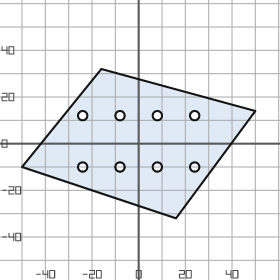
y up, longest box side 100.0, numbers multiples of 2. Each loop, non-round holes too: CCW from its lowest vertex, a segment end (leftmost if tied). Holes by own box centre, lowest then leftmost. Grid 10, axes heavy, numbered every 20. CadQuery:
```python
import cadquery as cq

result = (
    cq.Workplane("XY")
    .moveTo(16.0, -32.0)
    .lineTo(50.0, 14.0)
    .lineTo(-16.0, 32.0)
    .lineTo(-50.0, -10.0)
    .close()
    .moveTo(-24.0, -10.0)
    .circle(2.0)
    .moveTo(-8.0, -10.0)
    .circle(2.0)
    .moveTo(8.0, -10.0)
    .circle(2.0)
    .moveTo(24.0, -10.0)
    .circle(2.0)
    .moveTo(-24.0, 12.0)
    .circle(2.0)
    .moveTo(-8.0, 12.0)
    .circle(2.0)
    .moveTo(8.0, 12.0)
    .circle(2.0)
    .moveTo(24.0, 12.0)
    .circle(2.0)
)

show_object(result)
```